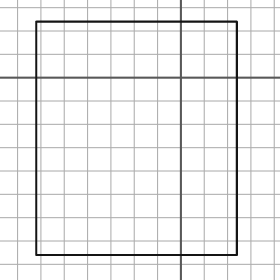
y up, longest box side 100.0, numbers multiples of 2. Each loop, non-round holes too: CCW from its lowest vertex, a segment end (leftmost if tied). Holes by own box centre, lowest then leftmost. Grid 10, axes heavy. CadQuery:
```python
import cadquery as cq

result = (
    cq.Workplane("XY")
    .moveTo(-62.0, -76.0)
    .lineTo(24.0, -76.0)
    .lineTo(24.0, 24.0)
    .lineTo(-62.0, 24.0)
    .close()
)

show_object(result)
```